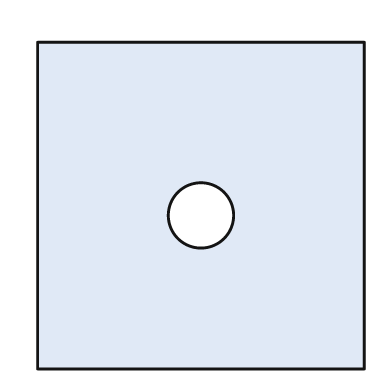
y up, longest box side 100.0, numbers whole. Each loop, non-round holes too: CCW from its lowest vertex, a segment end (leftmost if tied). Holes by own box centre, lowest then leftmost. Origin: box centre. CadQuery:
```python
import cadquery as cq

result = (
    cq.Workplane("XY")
    .moveTo(-50.0, -50.0)
    .lineTo(50.0, -50.0)
    .lineTo(50.0, 50.0)
    .lineTo(-50.0, 50.0)
    .close()
    .moveTo(0.0, -3.0)
    .circle(10.0)
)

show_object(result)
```